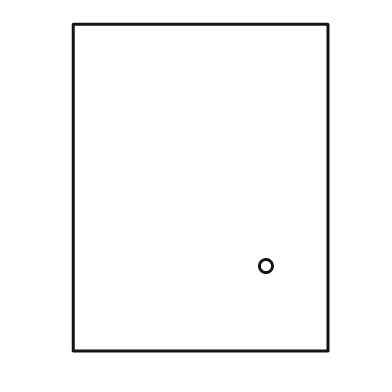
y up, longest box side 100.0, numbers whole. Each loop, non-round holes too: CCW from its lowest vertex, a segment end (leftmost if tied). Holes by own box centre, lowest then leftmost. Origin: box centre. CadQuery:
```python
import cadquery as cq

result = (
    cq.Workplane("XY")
    .moveTo(-39.0, -50.0)
    .lineTo(39.0, -50.0)
    .lineTo(39.0, 50.0)
    .lineTo(-39.0, 50.0)
    .close()
    .moveTo(20.0, -24.0)
    .circle(2.0)
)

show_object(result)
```